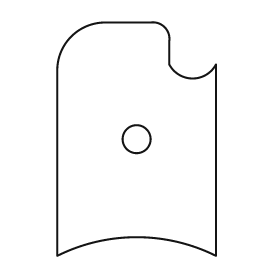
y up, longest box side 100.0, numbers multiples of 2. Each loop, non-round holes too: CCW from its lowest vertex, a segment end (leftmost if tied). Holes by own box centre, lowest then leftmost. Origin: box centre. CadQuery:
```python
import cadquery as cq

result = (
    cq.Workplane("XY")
    .moveTo(-34.0, -50.0)
    .threePointArc((0.0, -42.0), (34.0, -50.0))
    .lineTo(34.0, 32.0)
    .threePointArc((24.0, 26.0), (14.0, 32.0))
    .lineTo(14.0, 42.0)
    .threePointArc((12.0, 48.0), (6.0, 50.0))
    .lineTo(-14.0, 50.0)
    .threePointArc((-28.0, 44.0), (-34.0, 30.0))
    .close()
    .moveTo(0.0, 0.0)
    .circle(6.0)
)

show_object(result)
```